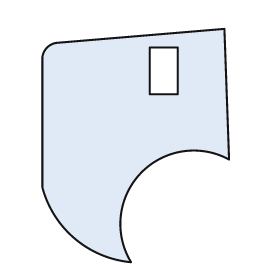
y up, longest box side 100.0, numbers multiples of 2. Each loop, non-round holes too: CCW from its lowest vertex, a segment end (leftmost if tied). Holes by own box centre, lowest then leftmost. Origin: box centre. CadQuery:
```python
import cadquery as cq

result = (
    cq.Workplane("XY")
    .moveTo(-2.0, -50.0)
    .threePointArc((2.0, -12.0), (40.0, -6.0))
    .lineTo(38.0, 50.0)
    .lineTo(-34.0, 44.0)
    .threePointArc((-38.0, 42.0), (-40.0, 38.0))
    .lineTo(-40.0, -18.0)
    .threePointArc((-26.0, -40.0), (-2.0, -50.0))
    .close()
    .moveTo(6.0, 22.0)
    .lineTo(18.0, 22.0)
    .lineTo(18.0, 42.0)
    .lineTo(6.0, 42.0)
    .close()
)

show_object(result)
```